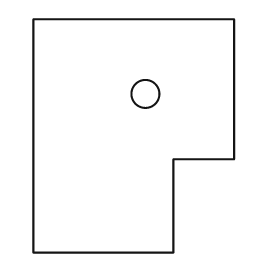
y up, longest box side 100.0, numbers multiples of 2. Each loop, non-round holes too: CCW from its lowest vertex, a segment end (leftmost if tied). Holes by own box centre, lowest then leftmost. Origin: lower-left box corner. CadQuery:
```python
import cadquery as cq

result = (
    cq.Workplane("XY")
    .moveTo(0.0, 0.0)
    .lineTo(60.0, 0.0)
    .lineTo(60.0, 40.0)
    .lineTo(86.0, 40.0)
    .lineTo(86.0, 100.0)
    .lineTo(0.0, 100.0)
    .close()
    .moveTo(48.0, 68.0)
    .circle(6.0)
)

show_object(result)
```